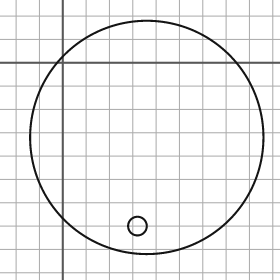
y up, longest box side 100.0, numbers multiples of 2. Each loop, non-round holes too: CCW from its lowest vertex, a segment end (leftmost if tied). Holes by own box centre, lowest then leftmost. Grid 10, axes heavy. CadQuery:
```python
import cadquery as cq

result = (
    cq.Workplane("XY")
    .moveTo(36.0, -32.0)
    .circle(50.0)
    .moveTo(32.0, -70.0)
    .circle(4.0)
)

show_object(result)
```